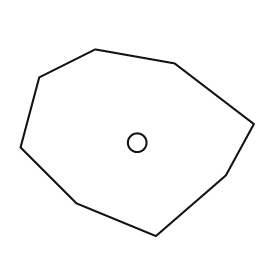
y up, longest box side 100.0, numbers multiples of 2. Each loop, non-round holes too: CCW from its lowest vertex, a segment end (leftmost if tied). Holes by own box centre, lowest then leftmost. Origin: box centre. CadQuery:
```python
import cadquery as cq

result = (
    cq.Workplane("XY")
    .moveTo(8.0, -40.0)
    .lineTo(38.0, -14.0)
    .lineTo(50.0, 8.0)
    .lineTo(16.0, 34.0)
    .lineTo(-18.0, 40.0)
    .lineTo(-42.0, 28.0)
    .lineTo(-50.0, -2.0)
    .lineTo(-26.0, -26.0)
    .close()
    .moveTo(0.0, 0.0)
    .circle(4.0)
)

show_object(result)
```